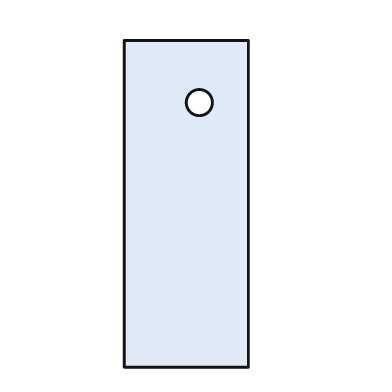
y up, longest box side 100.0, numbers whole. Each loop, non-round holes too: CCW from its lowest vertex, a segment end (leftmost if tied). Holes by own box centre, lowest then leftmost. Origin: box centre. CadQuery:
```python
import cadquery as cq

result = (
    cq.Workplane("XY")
    .moveTo(-19.0, -50.0)
    .lineTo(19.0, -50.0)
    .lineTo(19.0, 50.0)
    .lineTo(-19.0, 50.0)
    .close()
    .moveTo(4.0, 31.0)
    .circle(4.0)
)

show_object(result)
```